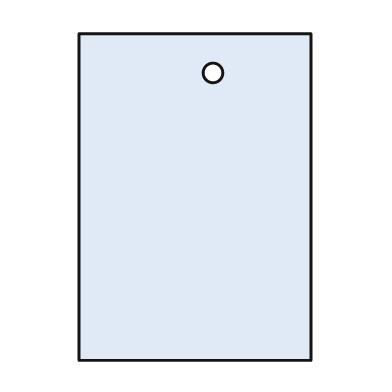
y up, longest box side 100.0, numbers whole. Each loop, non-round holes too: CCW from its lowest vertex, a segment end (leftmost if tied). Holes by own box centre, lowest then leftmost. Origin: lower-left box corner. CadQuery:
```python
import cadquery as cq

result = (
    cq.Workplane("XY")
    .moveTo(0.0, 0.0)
    .lineTo(71.0, 0.0)
    .lineTo(71.0, 100.0)
    .lineTo(0.0, 100.0)
    .close()
    .moveTo(41.0, 88.0)
    .circle(3.0)
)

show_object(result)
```